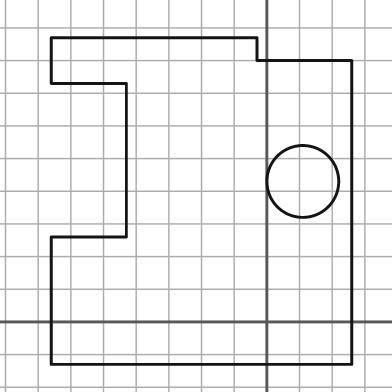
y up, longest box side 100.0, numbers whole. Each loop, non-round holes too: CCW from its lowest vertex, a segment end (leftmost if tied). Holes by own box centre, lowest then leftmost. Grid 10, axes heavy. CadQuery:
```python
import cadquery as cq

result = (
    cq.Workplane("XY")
    .moveTo(-66.0, -13.0)
    .lineTo(26.0, -13.0)
    .lineTo(26.0, 80.0)
    .lineTo(-3.0, 80.0)
    .lineTo(-3.0, 87.0)
    .lineTo(-66.0, 87.0)
    .lineTo(-66.0, 73.0)
    .lineTo(-43.0, 73.0)
    .lineTo(-43.0, 26.0)
    .lineTo(-66.0, 26.0)
    .close()
    .moveTo(11.0, 43.0)
    .circle(11.0)
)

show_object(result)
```